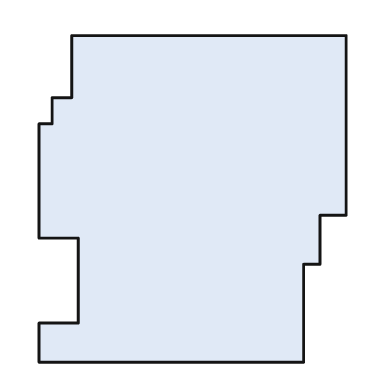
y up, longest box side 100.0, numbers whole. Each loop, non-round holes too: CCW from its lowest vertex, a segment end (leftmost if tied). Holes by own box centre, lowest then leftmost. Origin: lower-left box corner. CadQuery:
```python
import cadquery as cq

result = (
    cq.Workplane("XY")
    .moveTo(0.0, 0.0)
    .lineTo(81.0, 0.0)
    .lineTo(81.0, 30.0)
    .lineTo(86.0, 30.0)
    .lineTo(86.0, 45.0)
    .lineTo(94.0, 45.0)
    .lineTo(94.0, 100.0)
    .lineTo(10.0, 100.0)
    .lineTo(10.0, 81.0)
    .lineTo(4.0, 81.0)
    .lineTo(4.0, 73.0)
    .lineTo(0.0, 73.0)
    .lineTo(0.0, 38.0)
    .lineTo(12.0, 38.0)
    .lineTo(12.0, 12.0)
    .lineTo(0.0, 12.0)
    .close()
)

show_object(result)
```